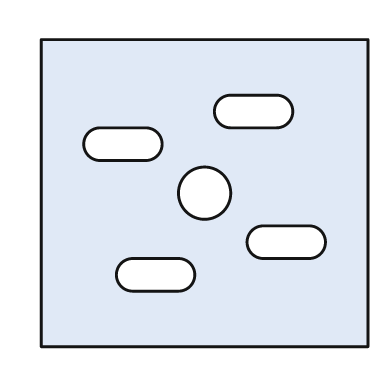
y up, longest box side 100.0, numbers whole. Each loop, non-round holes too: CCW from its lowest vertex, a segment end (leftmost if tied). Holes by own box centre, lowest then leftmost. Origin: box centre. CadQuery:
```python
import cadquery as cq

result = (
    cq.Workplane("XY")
    .moveTo(-50.0, -47.0)
    .lineTo(50.0, -47.0)
    .lineTo(50.0, 47.0)
    .lineTo(-50.0, 47.0)
    .close()
    .moveTo(-22.0, -30.0)
    .lineTo(-8.0, -30.0)
    .threePointArc((-3.0, -25.0), (-8.0, -20.0))
    .lineTo(-22.0, -20.0)
    .threePointArc((-27.0, -25.0), (-22.0, -30.0))
    .close()
    .moveTo(18.0, -20.0)
    .lineTo(32.0, -20.0)
    .threePointArc((37.0, -15.0), (32.0, -10.0))
    .lineTo(18.0, -10.0)
    .threePointArc((13.0, -15.0), (18.0, -20.0))
    .close()
    .moveTo(0.0, 0.0)
    .circle(8.0)
    .moveTo(-32.0, 10.0)
    .lineTo(-18.0, 10.0)
    .threePointArc((-13.0, 15.0), (-18.0, 20.0))
    .lineTo(-32.0, 20.0)
    .threePointArc((-37.0, 15.0), (-32.0, 10.0))
    .close()
    .moveTo(8.0, 20.0)
    .lineTo(22.0, 20.0)
    .threePointArc((27.0, 25.0), (22.0, 30.0))
    .lineTo(8.0, 30.0)
    .threePointArc((3.0, 25.0), (8.0, 20.0))
    .close()
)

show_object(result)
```